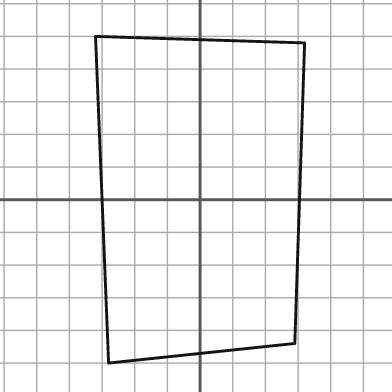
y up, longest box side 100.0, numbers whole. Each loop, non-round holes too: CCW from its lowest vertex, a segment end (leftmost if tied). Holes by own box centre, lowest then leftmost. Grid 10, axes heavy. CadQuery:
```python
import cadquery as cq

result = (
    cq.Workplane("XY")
    .moveTo(-28.0, -50.0)
    .lineTo(29.0, -44.0)
    .lineTo(32.0, 48.0)
    .lineTo(-32.0, 50.0)
    .close()
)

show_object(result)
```